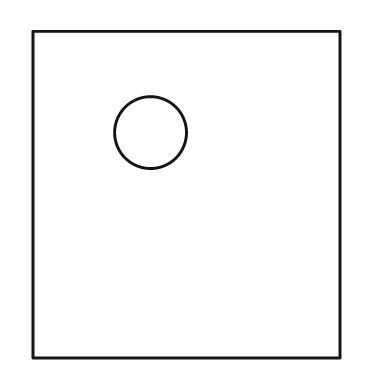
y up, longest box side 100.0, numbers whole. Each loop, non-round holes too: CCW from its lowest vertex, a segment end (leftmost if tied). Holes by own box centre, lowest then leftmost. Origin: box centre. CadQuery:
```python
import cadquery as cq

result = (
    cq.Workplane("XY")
    .moveTo(-47.0, -50.0)
    .lineTo(47.0, -50.0)
    .lineTo(47.0, 50.0)
    .lineTo(-47.0, 50.0)
    .close()
    .moveTo(-11.0, 19.0)
    .circle(11.0)
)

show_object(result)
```